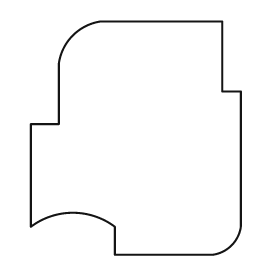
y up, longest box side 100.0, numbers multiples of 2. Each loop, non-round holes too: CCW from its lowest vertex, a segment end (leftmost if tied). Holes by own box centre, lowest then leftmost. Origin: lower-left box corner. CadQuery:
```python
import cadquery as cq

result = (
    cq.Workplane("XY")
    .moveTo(36.0, 0.0)
    .lineTo(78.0, 0.0)
    .threePointArc((86.0, 4.0), (90.0, 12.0))
    .lineTo(90.0, 70.0)
    .lineTo(82.0, 70.0)
    .lineTo(82.0, 100.0)
    .lineTo(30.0, 100.0)
    .threePointArc((18.0, 94.0), (12.0, 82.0))
    .lineTo(12.0, 56.0)
    .lineTo(0.0, 56.0)
    .lineTo(0.0, 12.0)
    .threePointArc((18.0, 18.0), (36.0, 12.0))
    .close()
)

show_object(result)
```